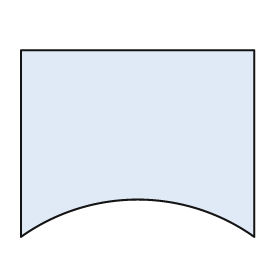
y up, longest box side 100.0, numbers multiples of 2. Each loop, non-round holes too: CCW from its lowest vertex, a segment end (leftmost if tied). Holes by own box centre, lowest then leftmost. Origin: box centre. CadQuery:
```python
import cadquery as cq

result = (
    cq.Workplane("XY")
    .moveTo(-50.0, -40.0)
    .threePointArc((0.0, -24.0), (50.0, -40.0))
    .lineTo(50.0, 40.0)
    .lineTo(-50.0, 40.0)
    .close()
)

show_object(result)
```